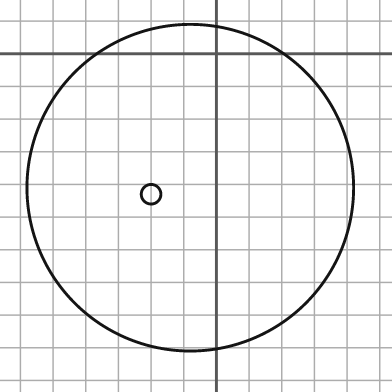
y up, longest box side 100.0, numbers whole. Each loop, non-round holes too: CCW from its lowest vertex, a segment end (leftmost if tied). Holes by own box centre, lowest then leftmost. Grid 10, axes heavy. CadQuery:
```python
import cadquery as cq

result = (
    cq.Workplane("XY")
    .moveTo(-8.0, -41.0)
    .circle(50.0)
    .moveTo(-20.0, -43.0)
    .circle(3.0)
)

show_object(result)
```